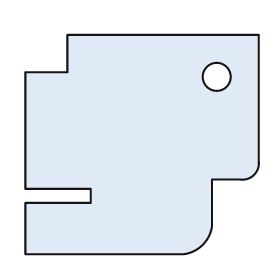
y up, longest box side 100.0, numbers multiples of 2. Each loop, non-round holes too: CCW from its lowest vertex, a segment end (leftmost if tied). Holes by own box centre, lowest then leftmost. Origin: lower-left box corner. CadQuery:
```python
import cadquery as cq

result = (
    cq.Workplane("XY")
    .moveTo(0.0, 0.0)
    .lineTo(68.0, 0.0)
    .threePointArc((76.0, 4.0), (80.0, 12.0))
    .lineTo(80.0, 32.0)
    .lineTo(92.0, 32.0)
    .threePointArc((98.0, 34.0), (100.0, 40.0))
    .lineTo(100.0, 94.0)
    .lineTo(18.0, 94.0)
    .lineTo(18.0, 78.0)
    .lineTo(0.0, 78.0)
    .lineTo(0.0, 28.0)
    .lineTo(28.0, 28.0)
    .lineTo(28.0, 22.0)
    .lineTo(0.0, 22.0)
    .close()
    .moveTo(82.0, 76.0)
    .circle(6.0)
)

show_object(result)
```